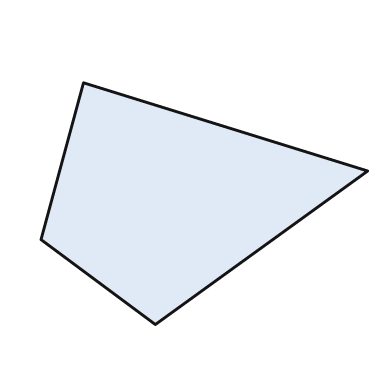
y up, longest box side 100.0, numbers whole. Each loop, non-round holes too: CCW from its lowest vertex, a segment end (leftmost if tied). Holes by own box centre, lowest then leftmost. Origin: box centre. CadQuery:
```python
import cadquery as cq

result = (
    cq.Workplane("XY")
    .moveTo(-15.0, -37.0)
    .lineTo(50.0, 10.0)
    .lineTo(-37.0, 37.0)
    .lineTo(-50.0, -11.0)
    .close()
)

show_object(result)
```